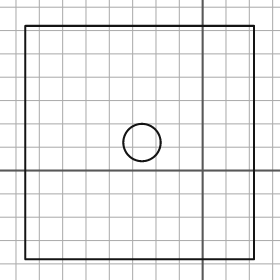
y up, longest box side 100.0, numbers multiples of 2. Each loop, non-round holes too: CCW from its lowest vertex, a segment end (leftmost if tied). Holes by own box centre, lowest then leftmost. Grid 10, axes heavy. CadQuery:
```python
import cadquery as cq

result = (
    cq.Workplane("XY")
    .moveTo(-76.0, -38.0)
    .lineTo(22.0, -38.0)
    .lineTo(22.0, 62.0)
    .lineTo(-76.0, 62.0)
    .close()
    .moveTo(-26.0, 12.0)
    .circle(8.0)
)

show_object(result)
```